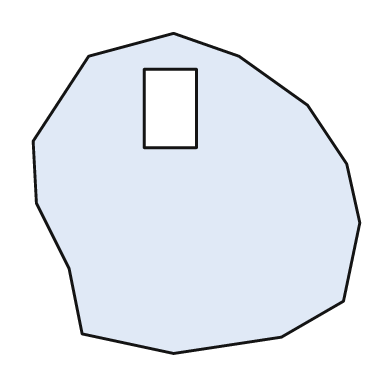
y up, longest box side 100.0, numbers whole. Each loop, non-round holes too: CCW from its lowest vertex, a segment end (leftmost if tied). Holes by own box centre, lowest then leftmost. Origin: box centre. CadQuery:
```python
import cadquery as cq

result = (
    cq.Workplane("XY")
    .moveTo(-7.0, -49.0)
    .lineTo(26.0, -44.0)
    .lineTo(45.0, -33.0)
    .lineTo(50.0, -9.0)
    .lineTo(46.0, 9.0)
    .lineTo(34.0, 27.0)
    .lineTo(13.0, 42.0)
    .lineTo(-7.0, 49.0)
    .lineTo(-33.0, 42.0)
    .lineTo(-50.0, 16.0)
    .lineTo(-49.0, -3.0)
    .lineTo(-39.0, -23.0)
    .lineTo(-35.0, -43.0)
    .close()
    .moveTo(-16.0, 14.0)
    .lineTo(0.0, 14.0)
    .lineTo(0.0, 38.0)
    .lineTo(-16.0, 38.0)
    .close()
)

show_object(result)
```